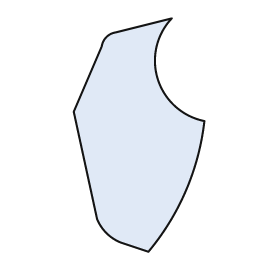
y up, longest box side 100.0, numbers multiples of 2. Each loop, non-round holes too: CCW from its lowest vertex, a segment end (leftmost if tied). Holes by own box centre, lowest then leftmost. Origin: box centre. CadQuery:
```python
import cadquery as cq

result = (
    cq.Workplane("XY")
    .moveTo(4.0, -50.0)
    .threePointArc((20.0, -24.0), (28.0, 6.0))
    .threePointArc((8.0, 24.0), (14.0, 50.0))
    .lineTo(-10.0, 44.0)
    .threePointArc((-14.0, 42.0), (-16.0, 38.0))
    .lineTo(-28.0, 10.0)
    .lineTo(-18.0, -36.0)
    .threePointArc((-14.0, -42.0), (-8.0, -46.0))
    .close()
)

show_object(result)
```